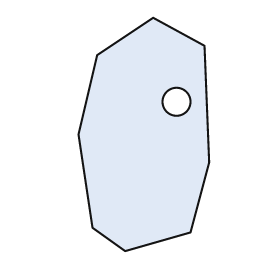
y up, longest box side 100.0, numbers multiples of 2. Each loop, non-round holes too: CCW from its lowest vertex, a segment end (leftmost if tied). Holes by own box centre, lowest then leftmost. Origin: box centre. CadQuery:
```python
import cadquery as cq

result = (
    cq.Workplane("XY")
    .moveTo(-8.0, -50.0)
    .lineTo(20.0, -42.0)
    .lineTo(28.0, -12.0)
    .lineTo(26.0, 38.0)
    .lineTo(4.0, 50.0)
    .lineTo(-20.0, 34.0)
    .lineTo(-28.0, 0.0)
    .lineTo(-22.0, -40.0)
    .close()
    .moveTo(14.0, 14.0)
    .circle(6.0)
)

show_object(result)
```